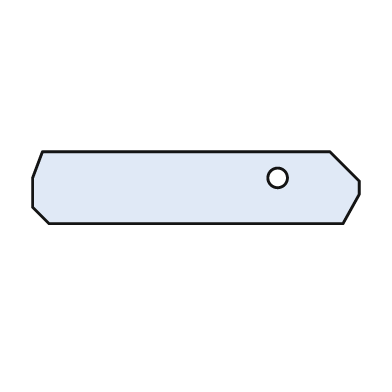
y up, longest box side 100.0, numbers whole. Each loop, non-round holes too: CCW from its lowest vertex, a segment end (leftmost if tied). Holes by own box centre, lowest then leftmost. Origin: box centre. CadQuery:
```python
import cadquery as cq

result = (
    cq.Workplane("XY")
    .moveTo(-45.0, -11.0)
    .lineTo(45.0, -11.0)
    .lineTo(50.0, -2.0)
    .lineTo(50.0, 2.0)
    .lineTo(41.0, 11.0)
    .lineTo(-47.0, 11.0)
    .lineTo(-50.0, 3.0)
    .lineTo(-50.0, -6.0)
    .close()
    .moveTo(25.0, 3.0)
    .circle(3.0)
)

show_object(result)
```